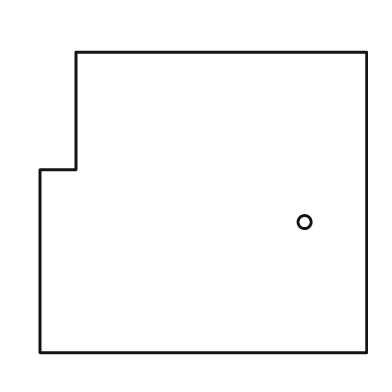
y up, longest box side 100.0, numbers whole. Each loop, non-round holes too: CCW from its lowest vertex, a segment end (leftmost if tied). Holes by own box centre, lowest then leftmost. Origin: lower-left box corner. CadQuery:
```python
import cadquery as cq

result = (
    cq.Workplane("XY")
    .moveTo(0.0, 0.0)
    .lineTo(100.0, 0.0)
    .lineTo(100.0, 92.0)
    .lineTo(11.0, 92.0)
    .lineTo(11.0, 56.0)
    .lineTo(0.0, 56.0)
    .close()
    .moveTo(81.0, 40.0)
    .circle(2.0)
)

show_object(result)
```